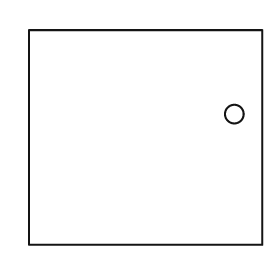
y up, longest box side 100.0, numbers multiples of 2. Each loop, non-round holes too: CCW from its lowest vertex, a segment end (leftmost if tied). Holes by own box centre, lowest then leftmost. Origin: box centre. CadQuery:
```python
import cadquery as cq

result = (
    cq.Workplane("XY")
    .moveTo(-50.0, -46.0)
    .lineTo(50.0, -46.0)
    .lineTo(50.0, 46.0)
    .lineTo(-50.0, 46.0)
    .close()
    .moveTo(38.0, 10.0)
    .circle(4.0)
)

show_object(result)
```